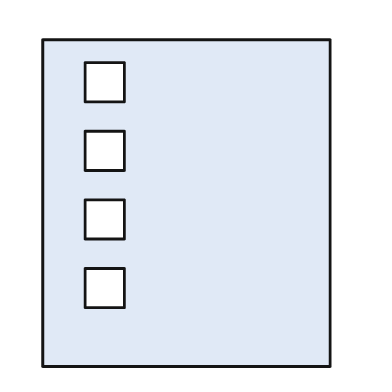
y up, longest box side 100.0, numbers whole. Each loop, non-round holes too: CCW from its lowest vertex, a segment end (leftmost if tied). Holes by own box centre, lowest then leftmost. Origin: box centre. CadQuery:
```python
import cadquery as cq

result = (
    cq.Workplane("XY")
    .moveTo(-44.0, -50.0)
    .lineTo(44.0, -50.0)
    .lineTo(44.0, 50.0)
    .lineTo(-44.0, 50.0)
    .close()
    .moveTo(-31.0, -32.0)
    .lineTo(-19.0, -32.0)
    .lineTo(-19.0, -20.0)
    .lineTo(-31.0, -20.0)
    .close()
    .moveTo(-31.0, -11.0)
    .lineTo(-19.0, -11.0)
    .lineTo(-19.0, 1.0)
    .lineTo(-31.0, 1.0)
    .close()
    .moveTo(-31.0, 10.0)
    .lineTo(-19.0, 10.0)
    .lineTo(-19.0, 22.0)
    .lineTo(-31.0, 22.0)
    .close()
    .moveTo(-31.0, 31.0)
    .lineTo(-19.0, 31.0)
    .lineTo(-19.0, 43.0)
    .lineTo(-31.0, 43.0)
    .close()
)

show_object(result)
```